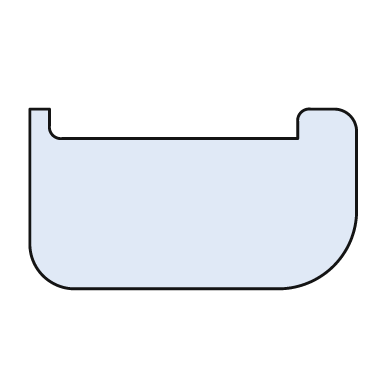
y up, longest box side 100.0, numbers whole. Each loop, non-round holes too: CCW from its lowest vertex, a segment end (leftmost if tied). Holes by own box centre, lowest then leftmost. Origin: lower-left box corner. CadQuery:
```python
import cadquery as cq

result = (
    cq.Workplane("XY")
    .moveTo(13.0, 0.0)
    .lineTo(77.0, 0.0)
    .threePointArc((93.0, 7.0), (100.0, 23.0))
    .lineTo(100.0, 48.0)
    .threePointArc((98.0, 53.0), (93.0, 55.0))
    .lineTo(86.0, 55.0)
    .threePointArc((83.0, 54.0), (82.0, 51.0))
    .lineTo(82.0, 46.0)
    .lineTo(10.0, 46.0)
    .threePointArc((7.0, 47.0), (6.0, 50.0))
    .lineTo(6.0, 55.0)
    .lineTo(0.0, 55.0)
    .lineTo(0.0, 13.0)
    .threePointArc((4.0, 4.0), (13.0, 0.0))
    .close()
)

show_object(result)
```